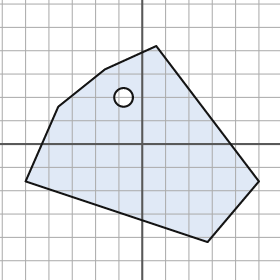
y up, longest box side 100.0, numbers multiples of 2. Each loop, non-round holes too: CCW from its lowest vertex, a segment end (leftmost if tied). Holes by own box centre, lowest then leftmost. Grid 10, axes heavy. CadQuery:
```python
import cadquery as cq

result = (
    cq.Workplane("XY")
    .moveTo(28.0, -42.0)
    .lineTo(50.0, -16.0)
    .lineTo(6.0, 42.0)
    .lineTo(-16.0, 32.0)
    .lineTo(-36.0, 16.0)
    .lineTo(-50.0, -16.0)
    .close()
    .moveTo(-8.0, 20.0)
    .circle(4.0)
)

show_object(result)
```